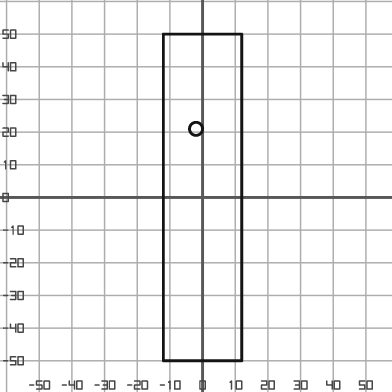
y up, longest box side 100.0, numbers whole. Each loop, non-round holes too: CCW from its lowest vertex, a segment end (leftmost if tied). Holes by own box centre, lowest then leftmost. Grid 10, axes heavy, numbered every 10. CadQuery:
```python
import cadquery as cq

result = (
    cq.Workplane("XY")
    .moveTo(-12.0, -50.0)
    .lineTo(12.0, -50.0)
    .lineTo(12.0, 50.0)
    .lineTo(-12.0, 50.0)
    .close()
    .moveTo(-2.0, 21.0)
    .circle(2.0)
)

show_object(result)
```